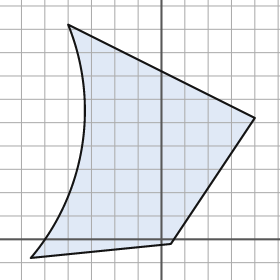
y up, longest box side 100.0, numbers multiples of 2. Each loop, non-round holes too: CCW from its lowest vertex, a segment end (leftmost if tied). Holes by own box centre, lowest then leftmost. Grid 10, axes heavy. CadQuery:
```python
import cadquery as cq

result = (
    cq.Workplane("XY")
    .moveTo(-56.0, -8.0)
    .lineTo(4.0, -2.0)
    .lineTo(40.0, 52.0)
    .lineTo(-40.0, 92.0)
    .threePointArc((-34.0, 40.0), (-56.0, -8.0))
    .close()
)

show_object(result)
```